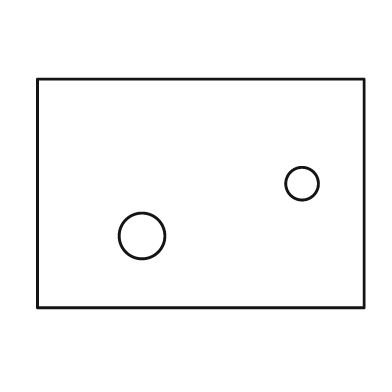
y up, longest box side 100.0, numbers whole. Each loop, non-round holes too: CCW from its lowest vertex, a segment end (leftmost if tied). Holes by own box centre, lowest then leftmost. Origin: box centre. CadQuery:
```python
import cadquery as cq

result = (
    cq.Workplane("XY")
    .moveTo(-50.0, -35.0)
    .lineTo(50.0, -35.0)
    .lineTo(50.0, 35.0)
    .lineTo(-50.0, 35.0)
    .close()
    .moveTo(-18.0, -13.0)
    .circle(7.0)
    .moveTo(31.0, 3.0)
    .circle(5.0)
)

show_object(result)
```